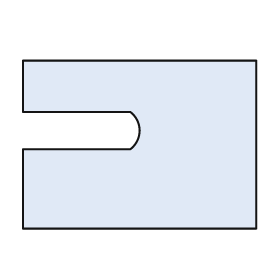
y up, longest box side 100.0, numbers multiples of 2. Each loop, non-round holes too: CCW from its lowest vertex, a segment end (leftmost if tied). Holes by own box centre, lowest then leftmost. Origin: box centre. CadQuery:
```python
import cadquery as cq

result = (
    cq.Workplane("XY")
    .moveTo(-50.0, -36.0)
    .lineTo(50.0, -36.0)
    .lineTo(50.0, 36.0)
    .lineTo(-50.0, 36.0)
    .lineTo(-50.0, 14.0)
    .lineTo(-4.0, 14.0)
    .threePointArc((0.0, 6.0), (-4.0, -2.0))
    .lineTo(-50.0, -2.0)
    .close()
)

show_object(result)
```